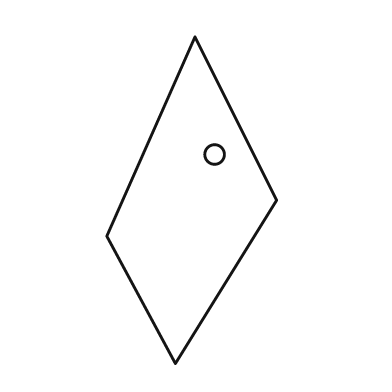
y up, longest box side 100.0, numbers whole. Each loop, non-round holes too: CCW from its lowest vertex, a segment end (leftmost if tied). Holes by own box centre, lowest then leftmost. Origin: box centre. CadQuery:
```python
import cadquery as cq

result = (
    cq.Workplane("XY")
    .moveTo(-5.0, -50.0)
    .lineTo(26.0, 0.0)
    .lineTo(1.0, 50.0)
    .lineTo(-26.0, -11.0)
    .close()
    .moveTo(7.0, 14.0)
    .circle(3.0)
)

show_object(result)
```